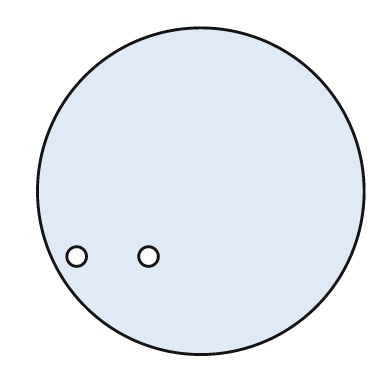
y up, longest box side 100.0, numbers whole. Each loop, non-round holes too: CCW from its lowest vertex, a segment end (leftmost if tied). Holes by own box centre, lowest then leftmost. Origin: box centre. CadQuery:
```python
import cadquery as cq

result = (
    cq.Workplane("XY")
    .moveTo(0.0, 0.0)
    .circle(50.0)
    .moveTo(-38.0, -20.0)
    .circle(3.0)
    .moveTo(-16.0, -20.0)
    .circle(3.0)
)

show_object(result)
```